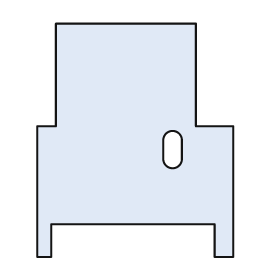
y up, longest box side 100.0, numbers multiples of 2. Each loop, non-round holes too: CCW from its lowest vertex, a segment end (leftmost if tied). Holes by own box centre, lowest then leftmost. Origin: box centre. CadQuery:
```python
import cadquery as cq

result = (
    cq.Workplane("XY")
    .moveTo(-42.0, -50.0)
    .lineTo(-36.0, -50.0)
    .lineTo(-36.0, -36.0)
    .lineTo(34.0, -36.0)
    .lineTo(34.0, -50.0)
    .lineTo(42.0, -50.0)
    .lineTo(42.0, 6.0)
    .lineTo(26.0, 6.0)
    .lineTo(26.0, 50.0)
    .lineTo(-34.0, 50.0)
    .lineTo(-34.0, 6.0)
    .lineTo(-42.0, 6.0)
    .close()
    .moveTo(12.0, -8.0)
    .threePointArc((16.0, -12.0), (20.0, -8.0))
    .lineTo(20.0, 0.0)
    .threePointArc((16.0, 4.0), (12.0, 0.0))
    .close()
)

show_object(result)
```